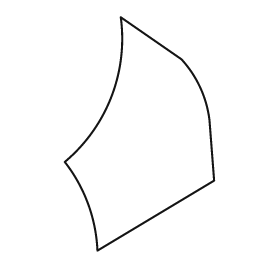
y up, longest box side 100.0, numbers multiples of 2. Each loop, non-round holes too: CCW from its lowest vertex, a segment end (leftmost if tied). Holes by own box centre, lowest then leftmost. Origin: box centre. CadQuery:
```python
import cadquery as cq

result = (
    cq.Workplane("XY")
    .moveTo(-18.0, -50.0)
    .lineTo(32.0, -20.0)
    .lineTo(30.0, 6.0)
    .threePointArc((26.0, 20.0), (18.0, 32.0))
    .lineTo(-8.0, 50.0)
    .threePointArc((-12.0, 16.0), (-32.0, -12.0))
    .threePointArc((-22.0, -30.0), (-18.0, -50.0))
    .close()
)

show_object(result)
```